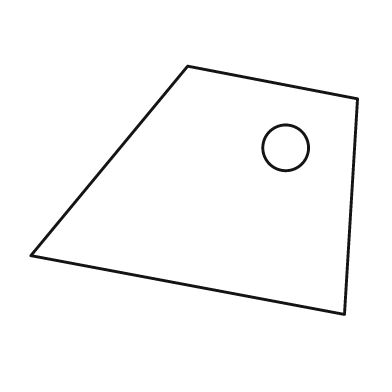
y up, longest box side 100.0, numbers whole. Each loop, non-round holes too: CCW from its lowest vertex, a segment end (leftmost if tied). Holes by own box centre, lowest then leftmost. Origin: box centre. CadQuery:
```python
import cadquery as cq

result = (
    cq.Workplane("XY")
    .moveTo(46.0, -38.0)
    .lineTo(50.0, 28.0)
    .lineTo(-2.0, 38.0)
    .lineTo(-50.0, -20.0)
    .close()
    .moveTo(28.0, 13.0)
    .circle(7.0)
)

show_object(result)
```